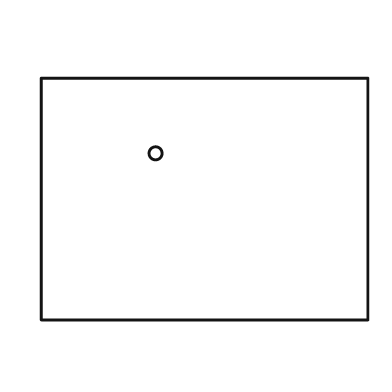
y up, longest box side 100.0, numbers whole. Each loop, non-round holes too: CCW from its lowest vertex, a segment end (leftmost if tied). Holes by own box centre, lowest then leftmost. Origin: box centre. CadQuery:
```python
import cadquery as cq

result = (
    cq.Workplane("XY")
    .moveTo(-50.0, -37.0)
    .lineTo(50.0, -37.0)
    .lineTo(50.0, 37.0)
    .lineTo(-50.0, 37.0)
    .close()
    .moveTo(-15.0, 14.0)
    .circle(2.0)
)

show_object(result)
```